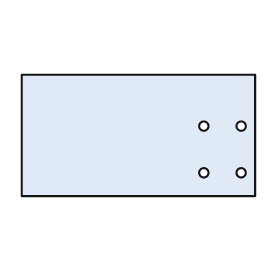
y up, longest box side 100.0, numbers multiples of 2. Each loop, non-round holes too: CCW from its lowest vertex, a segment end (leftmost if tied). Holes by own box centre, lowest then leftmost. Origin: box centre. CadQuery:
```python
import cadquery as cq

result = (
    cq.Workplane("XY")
    .moveTo(-50.0, -26.0)
    .lineTo(50.0, -26.0)
    .lineTo(50.0, 26.0)
    .lineTo(-50.0, 26.0)
    .close()
    .moveTo(28.0, -16.0)
    .circle(2.0)
    .moveTo(44.0, -16.0)
    .circle(2.0)
    .moveTo(28.0, 4.0)
    .circle(2.0)
    .moveTo(44.0, 4.0)
    .circle(2.0)
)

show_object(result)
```